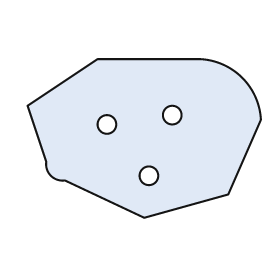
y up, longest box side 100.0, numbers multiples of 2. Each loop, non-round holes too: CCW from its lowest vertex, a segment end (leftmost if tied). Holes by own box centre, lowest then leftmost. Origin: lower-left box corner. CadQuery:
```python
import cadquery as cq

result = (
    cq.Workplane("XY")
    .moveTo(50.0, 0.0)
    .lineTo(86.0, 10.0)
    .lineTo(100.0, 42.0)
    .threePointArc((92.0, 60.0), (74.0, 68.0))
    .lineTo(30.0, 68.0)
    .lineTo(0.0, 48.0)
    .lineTo(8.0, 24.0)
    .threePointArc((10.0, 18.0), (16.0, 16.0))
    .close()
    .moveTo(52.0, 18.0)
    .circle(4.0)
    .moveTo(34.0, 40.0)
    .circle(4.0)
    .moveTo(62.0, 44.0)
    .circle(4.0)
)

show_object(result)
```